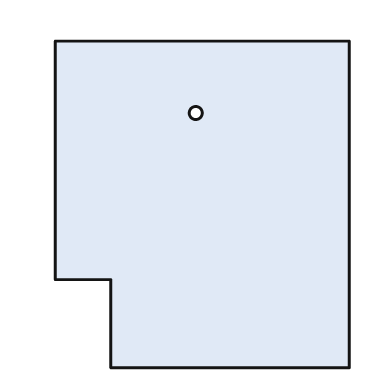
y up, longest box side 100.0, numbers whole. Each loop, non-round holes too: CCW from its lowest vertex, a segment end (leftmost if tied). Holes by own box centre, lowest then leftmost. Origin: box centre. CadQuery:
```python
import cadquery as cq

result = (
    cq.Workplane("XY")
    .moveTo(-28.0, -50.0)
    .lineTo(45.0, -50.0)
    .lineTo(45.0, 50.0)
    .lineTo(-45.0, 50.0)
    .lineTo(-45.0, -23.0)
    .lineTo(-28.0, -23.0)
    .close()
    .moveTo(-2.0, 28.0)
    .circle(2.0)
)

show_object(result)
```